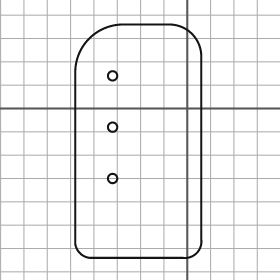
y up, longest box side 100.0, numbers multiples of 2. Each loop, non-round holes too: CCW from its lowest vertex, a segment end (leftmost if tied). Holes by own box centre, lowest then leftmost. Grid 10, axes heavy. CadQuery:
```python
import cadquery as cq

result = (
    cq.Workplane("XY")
    .moveTo(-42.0, -64.0)
    .lineTo(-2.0, -64.0)
    .threePointArc((4.0, -62.0), (6.0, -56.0))
    .lineTo(6.0, 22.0)
    .threePointArc((2.0, 32.0), (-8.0, 36.0))
    .lineTo(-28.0, 36.0)
    .threePointArc((-42.0, 30.0), (-48.0, 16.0))
    .lineTo(-48.0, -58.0)
    .threePointArc((-46.0, -62.0), (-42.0, -64.0))
    .close()
    .moveTo(-32.0, -30.0)
    .circle(2.0)
    .moveTo(-32.0, -8.0)
    .circle(2.0)
    .moveTo(-32.0, 14.0)
    .circle(2.0)
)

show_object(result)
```